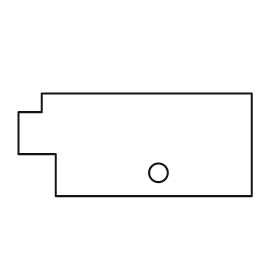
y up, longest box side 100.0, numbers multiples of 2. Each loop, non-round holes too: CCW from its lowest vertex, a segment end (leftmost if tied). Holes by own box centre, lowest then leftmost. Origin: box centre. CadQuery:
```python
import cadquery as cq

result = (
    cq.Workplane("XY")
    .moveTo(-34.0, -22.0)
    .lineTo(50.0, -22.0)
    .lineTo(50.0, 22.0)
    .lineTo(-40.0, 22.0)
    .lineTo(-40.0, 14.0)
    .lineTo(-50.0, 14.0)
    .lineTo(-50.0, -4.0)
    .lineTo(-34.0, -4.0)
    .close()
    .moveTo(10.0, -12.0)
    .circle(4.0)
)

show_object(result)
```